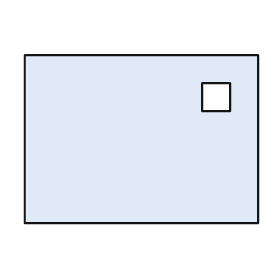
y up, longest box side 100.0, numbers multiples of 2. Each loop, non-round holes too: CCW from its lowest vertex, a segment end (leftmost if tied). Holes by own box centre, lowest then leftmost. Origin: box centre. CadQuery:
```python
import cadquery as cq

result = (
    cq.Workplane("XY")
    .moveTo(-50.0, -36.0)
    .lineTo(50.0, -36.0)
    .lineTo(50.0, 36.0)
    .lineTo(-50.0, 36.0)
    .close()
    .moveTo(26.0, 12.0)
    .lineTo(38.0, 12.0)
    .lineTo(38.0, 24.0)
    .lineTo(26.0, 24.0)
    .close()
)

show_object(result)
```